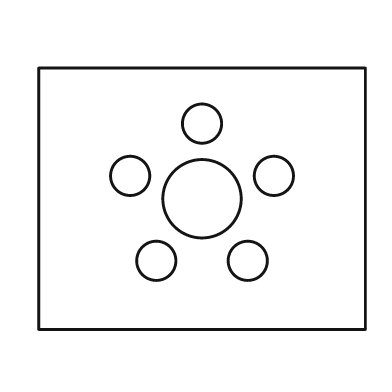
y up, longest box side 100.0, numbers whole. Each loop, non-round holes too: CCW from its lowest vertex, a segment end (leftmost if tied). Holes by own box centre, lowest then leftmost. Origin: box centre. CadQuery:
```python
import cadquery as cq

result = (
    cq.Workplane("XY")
    .moveTo(-50.0, -40.0)
    .lineTo(50.0, -40.0)
    .lineTo(50.0, 40.0)
    .lineTo(-50.0, 40.0)
    .close()
    .moveTo(-14.0, -19.0)
    .circle(6.0)
    .moveTo(14.0, -19.0)
    .circle(6.0)
    .moveTo(0.0, 0.0)
    .circle(12.0)
    .moveTo(-22.0, 7.0)
    .circle(6.0)
    .moveTo(22.0, 7.0)
    .circle(6.0)
    .moveTo(0.0, 23.0)
    .circle(6.0)
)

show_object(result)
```